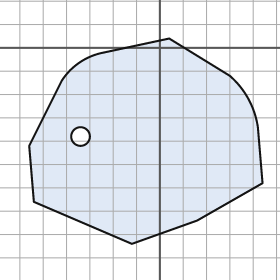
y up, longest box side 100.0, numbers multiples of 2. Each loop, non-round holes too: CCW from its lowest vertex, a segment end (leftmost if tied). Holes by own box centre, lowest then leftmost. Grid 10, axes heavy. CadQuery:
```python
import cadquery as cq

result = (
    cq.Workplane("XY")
    .moveTo(-12.0, -84.0)
    .lineTo(16.0, -74.0)
    .lineTo(44.0, -58.0)
    .lineTo(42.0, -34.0)
    .threePointArc((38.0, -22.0), (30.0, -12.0))
    .lineTo(4.0, 4.0)
    .lineTo(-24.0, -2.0)
    .threePointArc((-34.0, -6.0), (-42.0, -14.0))
    .lineTo(-56.0, -42.0)
    .lineTo(-54.0, -66.0)
    .close()
    .moveTo(-34.0, -38.0)
    .circle(4.0)
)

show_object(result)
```